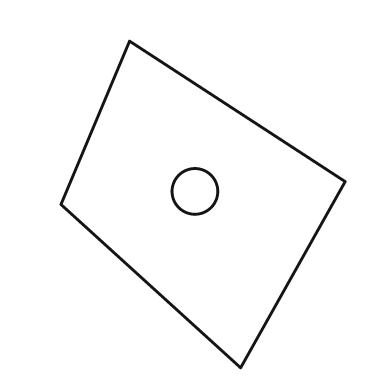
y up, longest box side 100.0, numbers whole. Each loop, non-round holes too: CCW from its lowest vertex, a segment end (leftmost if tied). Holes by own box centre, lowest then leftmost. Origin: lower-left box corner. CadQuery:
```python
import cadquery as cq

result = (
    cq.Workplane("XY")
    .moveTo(55.0, 0.0)
    .lineTo(87.0, 57.0)
    .lineTo(21.0, 100.0)
    .lineTo(0.0, 50.0)
    .close()
    .moveTo(41.0, 54.0)
    .circle(7.0)
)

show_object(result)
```